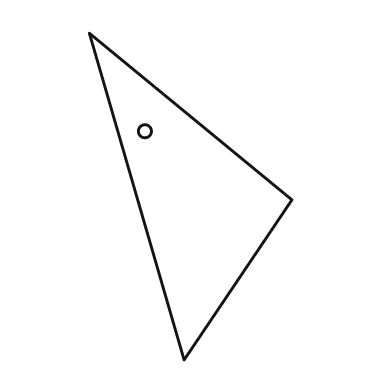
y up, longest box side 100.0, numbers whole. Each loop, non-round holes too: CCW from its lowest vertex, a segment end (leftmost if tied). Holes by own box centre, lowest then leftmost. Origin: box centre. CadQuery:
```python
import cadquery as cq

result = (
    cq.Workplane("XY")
    .moveTo(-2.0, -50.0)
    .lineTo(31.0, -1.0)
    .lineTo(-31.0, 50.0)
    .close()
    .moveTo(-14.0, 20.0)
    .circle(2.0)
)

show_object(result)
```